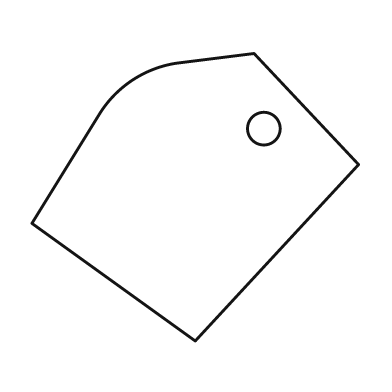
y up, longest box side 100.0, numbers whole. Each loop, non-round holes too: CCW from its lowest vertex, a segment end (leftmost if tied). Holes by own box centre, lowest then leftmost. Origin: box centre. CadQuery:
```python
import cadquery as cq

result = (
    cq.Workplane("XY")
    .moveTo(0.0, -44.0)
    .lineTo(50.0, 10.0)
    .lineTo(18.0, 44.0)
    .lineTo(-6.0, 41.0)
    .threePointArc((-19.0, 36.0), (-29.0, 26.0))
    .lineTo(-50.0, -8.0)
    .close()
    .moveTo(21.0, 21.0)
    .circle(5.0)
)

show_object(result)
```